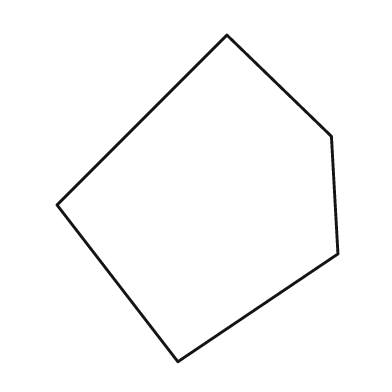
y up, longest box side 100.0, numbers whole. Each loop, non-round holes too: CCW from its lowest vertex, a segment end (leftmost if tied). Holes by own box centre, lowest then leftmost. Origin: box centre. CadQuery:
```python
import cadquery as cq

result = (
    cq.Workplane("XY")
    .moveTo(-6.0, -50.0)
    .lineTo(43.0, -17.0)
    .lineTo(41.0, 19.0)
    .lineTo(9.0, 50.0)
    .lineTo(-43.0, -2.0)
    .close()
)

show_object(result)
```